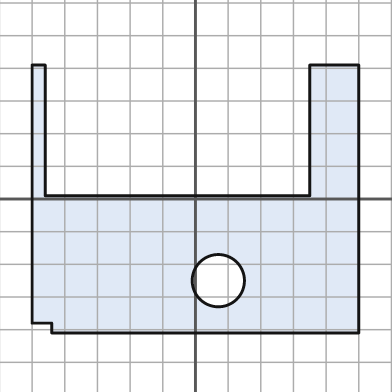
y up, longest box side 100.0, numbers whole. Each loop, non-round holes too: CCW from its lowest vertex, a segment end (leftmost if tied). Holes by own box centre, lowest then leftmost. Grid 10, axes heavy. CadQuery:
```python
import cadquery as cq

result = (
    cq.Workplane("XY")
    .moveTo(-44.0, -41.0)
    .lineTo(50.0, -41.0)
    .lineTo(50.0, 41.0)
    .lineTo(35.0, 41.0)
    .lineTo(35.0, 1.0)
    .lineTo(-46.0, 1.0)
    .lineTo(-46.0, 41.0)
    .lineTo(-50.0, 41.0)
    .lineTo(-50.0, -38.0)
    .lineTo(-44.0, -38.0)
    .close()
    .moveTo(7.0, -25.0)
    .circle(8.0)
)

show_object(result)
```